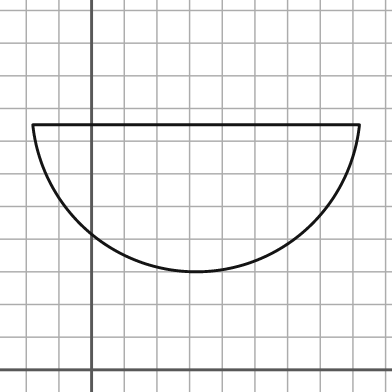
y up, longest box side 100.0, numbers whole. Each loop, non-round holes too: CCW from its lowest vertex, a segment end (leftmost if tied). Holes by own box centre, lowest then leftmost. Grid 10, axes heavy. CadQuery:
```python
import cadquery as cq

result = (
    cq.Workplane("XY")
    .moveTo(-18.0, 75.0)
    .threePointArc((32.0, 30.0), (82.0, 75.0))
    .close()
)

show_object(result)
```